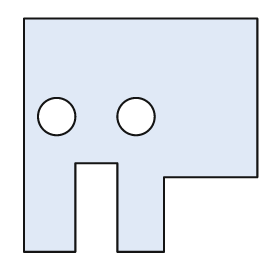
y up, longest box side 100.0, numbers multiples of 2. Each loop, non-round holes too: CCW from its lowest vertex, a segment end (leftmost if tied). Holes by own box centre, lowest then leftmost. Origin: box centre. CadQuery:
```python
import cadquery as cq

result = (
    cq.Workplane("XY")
    .moveTo(-50.0, -50.0)
    .lineTo(-28.0, -50.0)
    .lineTo(-28.0, -12.0)
    .lineTo(-10.0, -12.0)
    .lineTo(-10.0, -50.0)
    .lineTo(10.0, -50.0)
    .lineTo(10.0, -18.0)
    .lineTo(50.0, -18.0)
    .lineTo(50.0, 50.0)
    .lineTo(-50.0, 50.0)
    .close()
    .moveTo(-36.0, 8.0)
    .circle(8.0)
    .moveTo(-2.0, 8.0)
    .circle(8.0)
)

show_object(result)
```